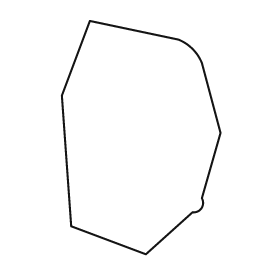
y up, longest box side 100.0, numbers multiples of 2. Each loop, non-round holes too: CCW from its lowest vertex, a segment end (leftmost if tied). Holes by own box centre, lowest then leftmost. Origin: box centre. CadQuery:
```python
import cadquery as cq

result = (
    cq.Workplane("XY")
    .moveTo(2.0, -50.0)
    .lineTo(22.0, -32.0)
    .threePointArc((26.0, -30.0), (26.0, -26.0))
    .lineTo(34.0, 2.0)
    .lineTo(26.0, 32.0)
    .threePointArc((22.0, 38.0), (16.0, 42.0))
    .lineTo(-22.0, 50.0)
    .lineTo(-34.0, 18.0)
    .lineTo(-30.0, -38.0)
    .close()
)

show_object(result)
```